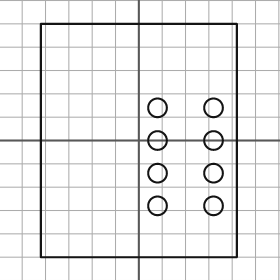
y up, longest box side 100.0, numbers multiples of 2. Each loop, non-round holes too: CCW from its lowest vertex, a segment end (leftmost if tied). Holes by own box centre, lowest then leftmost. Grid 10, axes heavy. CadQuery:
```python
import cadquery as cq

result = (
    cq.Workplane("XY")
    .moveTo(-42.0, -50.0)
    .lineTo(42.0, -50.0)
    .lineTo(42.0, 50.0)
    .lineTo(-42.0, 50.0)
    .close()
    .moveTo(8.0, -28.0)
    .circle(4.0)
    .moveTo(32.0, -28.0)
    .circle(4.0)
    .moveTo(8.0, -14.0)
    .circle(4.0)
    .moveTo(32.0, -14.0)
    .circle(4.0)
    .moveTo(8.0, 0.0)
    .circle(4.0)
    .moveTo(32.0, 0.0)
    .circle(4.0)
    .moveTo(8.0, 14.0)
    .circle(4.0)
    .moveTo(32.0, 14.0)
    .circle(4.0)
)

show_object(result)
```